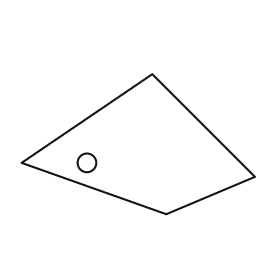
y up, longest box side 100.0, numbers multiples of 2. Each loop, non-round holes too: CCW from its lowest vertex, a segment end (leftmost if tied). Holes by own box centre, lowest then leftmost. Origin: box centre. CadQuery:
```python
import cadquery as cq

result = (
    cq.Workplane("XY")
    .moveTo(12.0, -30.0)
    .lineTo(50.0, -14.0)
    .lineTo(6.0, 30.0)
    .lineTo(-50.0, -8.0)
    .close()
    .moveTo(-22.0, -8.0)
    .circle(4.0)
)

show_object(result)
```